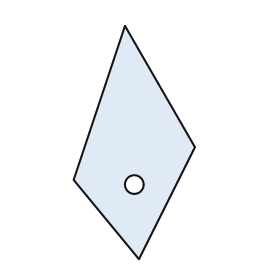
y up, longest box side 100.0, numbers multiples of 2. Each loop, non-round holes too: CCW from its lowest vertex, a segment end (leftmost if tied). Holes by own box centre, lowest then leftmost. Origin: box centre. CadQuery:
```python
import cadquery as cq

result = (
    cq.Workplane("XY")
    .moveTo(2.0, -50.0)
    .lineTo(26.0, -2.0)
    .lineTo(-4.0, 50.0)
    .lineTo(-26.0, -16.0)
    .close()
    .moveTo(0.0, -18.0)
    .circle(4.0)
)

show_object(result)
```